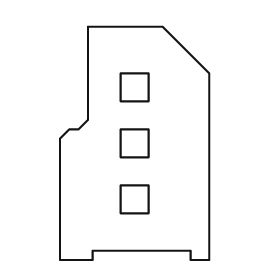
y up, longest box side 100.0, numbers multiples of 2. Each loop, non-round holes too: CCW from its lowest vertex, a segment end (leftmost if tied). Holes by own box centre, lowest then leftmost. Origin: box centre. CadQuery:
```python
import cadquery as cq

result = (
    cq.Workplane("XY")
    .moveTo(-32.0, -50.0)
    .lineTo(-18.0, -50.0)
    .lineTo(-18.0, -46.0)
    .lineTo(24.0, -46.0)
    .lineTo(24.0, -50.0)
    .lineTo(32.0, -50.0)
    .lineTo(32.0, 30.0)
    .lineTo(12.0, 50.0)
    .lineTo(-20.0, 50.0)
    .lineTo(-20.0, 10.0)
    .lineTo(-24.0, 6.0)
    .lineTo(-28.0, 6.0)
    .lineTo(-32.0, 2.0)
    .close()
    .moveTo(-6.0, -30.0)
    .lineTo(6.0, -30.0)
    .lineTo(6.0, -18.0)
    .lineTo(-6.0, -18.0)
    .close()
    .moveTo(-6.0, -6.0)
    .lineTo(6.0, -6.0)
    .lineTo(6.0, 6.0)
    .lineTo(-6.0, 6.0)
    .close()
    .moveTo(-6.0, 18.0)
    .lineTo(6.0, 18.0)
    .lineTo(6.0, 30.0)
    .lineTo(-6.0, 30.0)
    .close()
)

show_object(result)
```